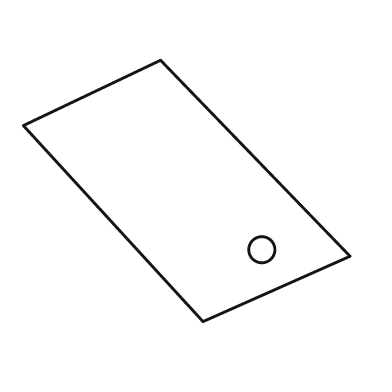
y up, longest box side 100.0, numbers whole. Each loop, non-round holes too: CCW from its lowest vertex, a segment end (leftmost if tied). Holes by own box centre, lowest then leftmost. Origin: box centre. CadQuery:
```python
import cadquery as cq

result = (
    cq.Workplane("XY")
    .moveTo(5.0, -40.0)
    .lineTo(50.0, -20.0)
    .lineTo(-8.0, 40.0)
    .lineTo(-50.0, 20.0)
    .close()
    .moveTo(23.0, -18.0)
    .circle(4.0)
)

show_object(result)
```